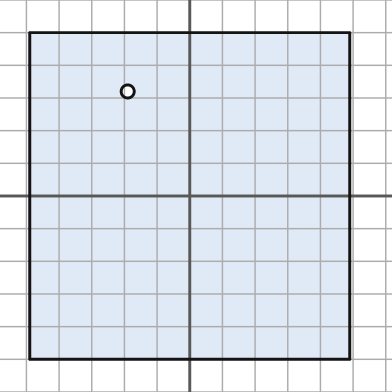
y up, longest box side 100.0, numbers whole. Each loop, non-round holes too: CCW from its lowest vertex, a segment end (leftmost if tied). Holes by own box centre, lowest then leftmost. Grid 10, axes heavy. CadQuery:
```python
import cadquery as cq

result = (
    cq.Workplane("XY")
    .moveTo(-49.0, -50.0)
    .lineTo(49.0, -50.0)
    .lineTo(49.0, 50.0)
    .lineTo(-49.0, 50.0)
    .close()
    .moveTo(-19.0, 32.0)
    .circle(2.0)
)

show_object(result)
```